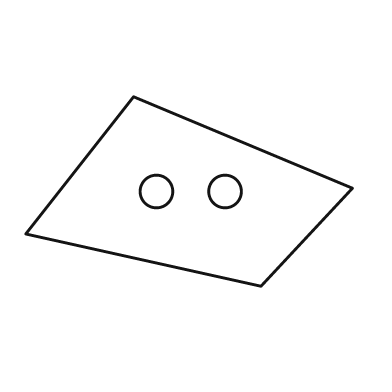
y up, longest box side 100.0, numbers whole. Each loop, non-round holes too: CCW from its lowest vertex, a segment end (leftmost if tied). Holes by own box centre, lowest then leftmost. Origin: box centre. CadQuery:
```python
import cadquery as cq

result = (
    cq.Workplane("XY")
    .moveTo(22.0, -29.0)
    .lineTo(50.0, 1.0)
    .lineTo(-17.0, 29.0)
    .lineTo(-50.0, -13.0)
    .close()
    .moveTo(-10.0, 0.0)
    .circle(5.0)
    .moveTo(11.0, 0.0)
    .circle(5.0)
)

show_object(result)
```